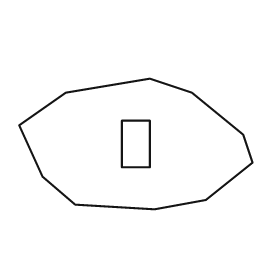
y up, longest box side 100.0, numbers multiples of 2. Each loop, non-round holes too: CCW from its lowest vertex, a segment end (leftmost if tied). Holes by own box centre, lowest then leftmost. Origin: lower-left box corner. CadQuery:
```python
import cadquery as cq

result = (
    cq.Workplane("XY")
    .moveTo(58.0, 0.0)
    .lineTo(80.0, 4.0)
    .lineTo(100.0, 20.0)
    .lineTo(96.0, 32.0)
    .lineTo(74.0, 50.0)
    .lineTo(56.0, 56.0)
    .lineTo(20.0, 50.0)
    .lineTo(0.0, 36.0)
    .lineTo(10.0, 14.0)
    .lineTo(24.0, 2.0)
    .close()
    .moveTo(44.0, 18.0)
    .lineTo(56.0, 18.0)
    .lineTo(56.0, 38.0)
    .lineTo(44.0, 38.0)
    .close()
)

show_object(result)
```